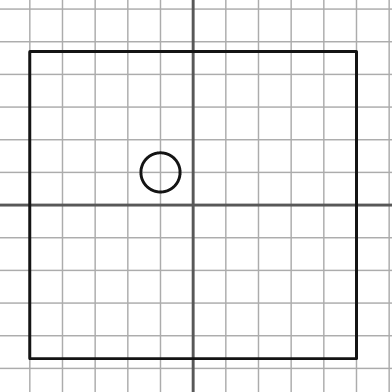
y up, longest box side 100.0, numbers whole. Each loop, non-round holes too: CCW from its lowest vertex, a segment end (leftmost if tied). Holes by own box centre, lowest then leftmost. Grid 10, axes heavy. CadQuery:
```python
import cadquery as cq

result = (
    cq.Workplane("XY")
    .moveTo(-50.0, -47.0)
    .lineTo(50.0, -47.0)
    .lineTo(50.0, 47.0)
    .lineTo(-50.0, 47.0)
    .close()
    .moveTo(-10.0, 10.0)
    .circle(6.0)
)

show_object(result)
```